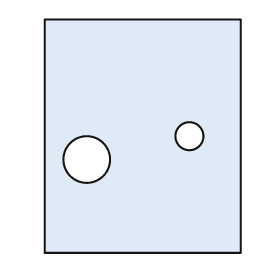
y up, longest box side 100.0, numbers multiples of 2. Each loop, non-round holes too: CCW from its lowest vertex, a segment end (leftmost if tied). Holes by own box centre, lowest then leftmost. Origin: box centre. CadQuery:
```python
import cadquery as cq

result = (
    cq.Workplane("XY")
    .moveTo(-42.0, -50.0)
    .lineTo(42.0, -50.0)
    .lineTo(42.0, 50.0)
    .lineTo(-42.0, 50.0)
    .close()
    .moveTo(-24.0, -10.0)
    .circle(10.0)
    .moveTo(20.0, 0.0)
    .circle(6.0)
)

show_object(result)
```